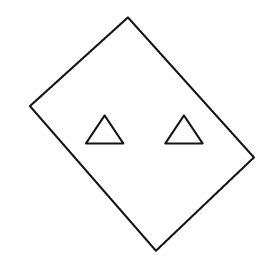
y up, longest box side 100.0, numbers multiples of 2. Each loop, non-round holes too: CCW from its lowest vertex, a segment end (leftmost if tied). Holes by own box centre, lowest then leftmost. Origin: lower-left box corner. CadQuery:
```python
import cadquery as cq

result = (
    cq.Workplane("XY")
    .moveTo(54.0, 0.0)
    .lineTo(96.0, 40.0)
    .lineTo(42.0, 100.0)
    .lineTo(0.0, 62.0)
    .close()
    .moveTo(24.0, 46.0)
    .lineTo(40.0, 46.0)
    .lineTo(32.0, 58.0)
    .close()
    .moveTo(58.0, 46.0)
    .lineTo(74.0, 46.0)
    .lineTo(66.0, 58.0)
    .close()
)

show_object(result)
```